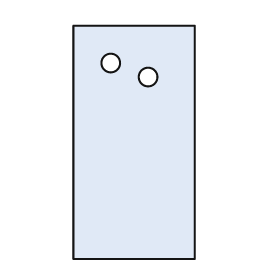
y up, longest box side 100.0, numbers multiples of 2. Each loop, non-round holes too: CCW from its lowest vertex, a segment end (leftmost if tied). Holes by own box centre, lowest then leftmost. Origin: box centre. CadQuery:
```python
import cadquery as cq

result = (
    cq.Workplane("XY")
    .moveTo(-26.0, -50.0)
    .lineTo(26.0, -50.0)
    .lineTo(26.0, 50.0)
    .lineTo(-26.0, 50.0)
    .close()
    .moveTo(6.0, 28.0)
    .circle(4.0)
    .moveTo(-10.0, 34.0)
    .circle(4.0)
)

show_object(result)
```